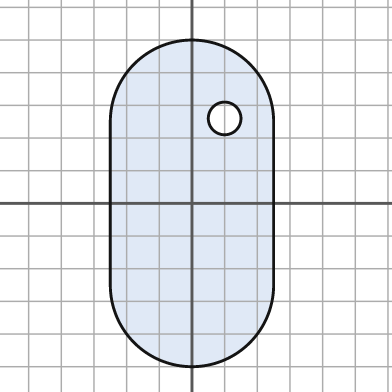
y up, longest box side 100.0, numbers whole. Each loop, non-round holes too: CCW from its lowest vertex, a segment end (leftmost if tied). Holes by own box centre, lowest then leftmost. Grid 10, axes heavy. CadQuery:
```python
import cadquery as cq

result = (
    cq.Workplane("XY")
    .moveTo(-25.0, -25.0)
    .threePointArc((0.0, -50.0), (25.0, -25.0))
    .lineTo(25.0, 25.0)
    .threePointArc((0.0, 50.0), (-25.0, 25.0))
    .close()
    .moveTo(10.0, 26.0)
    .circle(5.0)
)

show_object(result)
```